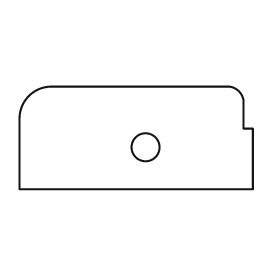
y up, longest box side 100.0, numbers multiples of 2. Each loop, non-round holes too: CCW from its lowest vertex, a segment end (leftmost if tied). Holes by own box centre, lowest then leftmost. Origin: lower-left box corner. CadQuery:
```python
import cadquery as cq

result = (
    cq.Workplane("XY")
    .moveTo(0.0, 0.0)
    .lineTo(100.0, 0.0)
    .lineTo(100.0, 26.0)
    .lineTo(96.0, 26.0)
    .lineTo(96.0, 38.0)
    .threePointArc((94.0, 42.0), (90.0, 44.0))
    .lineTo(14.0, 44.0)
    .threePointArc((4.0, 40.0), (0.0, 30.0))
    .close()
    .moveTo(54.0, 18.0)
    .circle(6.0)
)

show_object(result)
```